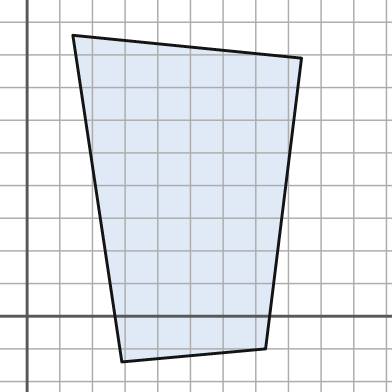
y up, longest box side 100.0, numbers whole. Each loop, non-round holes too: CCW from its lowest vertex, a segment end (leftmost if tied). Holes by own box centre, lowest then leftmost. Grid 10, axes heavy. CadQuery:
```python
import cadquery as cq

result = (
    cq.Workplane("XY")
    .moveTo(29.0, -14.0)
    .lineTo(73.0, -10.0)
    .lineTo(84.0, 79.0)
    .lineTo(14.0, 86.0)
    .close()
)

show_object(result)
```